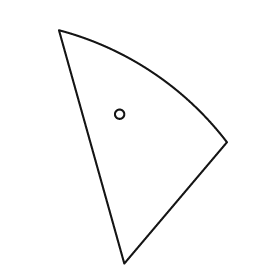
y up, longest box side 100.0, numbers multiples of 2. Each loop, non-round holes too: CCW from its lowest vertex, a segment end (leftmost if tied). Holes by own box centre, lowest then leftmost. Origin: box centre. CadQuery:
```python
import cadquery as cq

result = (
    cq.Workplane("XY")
    .moveTo(-8.0, -50.0)
    .lineTo(36.0, 2.0)
    .threePointArc((4.0, 32.0), (-36.0, 50.0))
    .close()
    .moveTo(-10.0, 14.0)
    .circle(2.0)
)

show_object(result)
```